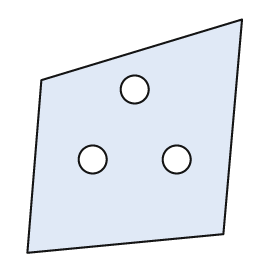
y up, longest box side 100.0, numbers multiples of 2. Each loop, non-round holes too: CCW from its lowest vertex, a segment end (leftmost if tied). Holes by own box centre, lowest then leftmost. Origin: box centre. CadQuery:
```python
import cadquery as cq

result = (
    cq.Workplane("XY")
    .moveTo(-46.0, -50.0)
    .lineTo(38.0, -42.0)
    .lineTo(46.0, 50.0)
    .lineTo(-40.0, 24.0)
    .close()
    .moveTo(-18.0, -10.0)
    .circle(6.0)
    .moveTo(18.0, -10.0)
    .circle(6.0)
    .moveTo(0.0, 20.0)
    .circle(6.0)
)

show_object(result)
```